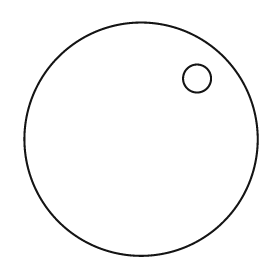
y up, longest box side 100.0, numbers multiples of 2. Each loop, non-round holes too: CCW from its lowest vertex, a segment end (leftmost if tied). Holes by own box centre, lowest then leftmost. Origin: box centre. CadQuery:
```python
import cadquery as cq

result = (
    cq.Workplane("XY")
    .moveTo(0.0, 0.0)
    .circle(50.0)
    .moveTo(24.0, 26.0)
    .circle(6.0)
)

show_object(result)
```